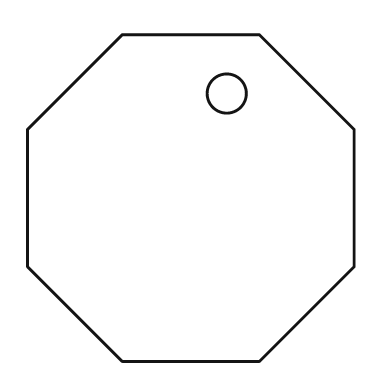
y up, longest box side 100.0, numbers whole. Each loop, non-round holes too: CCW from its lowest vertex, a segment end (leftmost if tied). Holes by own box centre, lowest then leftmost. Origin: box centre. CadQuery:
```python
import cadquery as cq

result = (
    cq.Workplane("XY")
    .moveTo(-21.0, -50.0)
    .lineTo(21.0, -50.0)
    .lineTo(50.0, -21.0)
    .lineTo(50.0, 21.0)
    .lineTo(21.0, 50.0)
    .lineTo(-21.0, 50.0)
    .lineTo(-50.0, 21.0)
    .lineTo(-50.0, -21.0)
    .close()
    .moveTo(11.0, 32.0)
    .circle(6.0)
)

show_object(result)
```